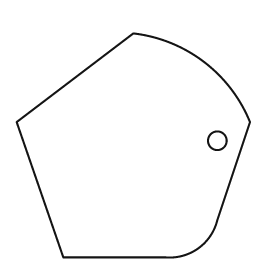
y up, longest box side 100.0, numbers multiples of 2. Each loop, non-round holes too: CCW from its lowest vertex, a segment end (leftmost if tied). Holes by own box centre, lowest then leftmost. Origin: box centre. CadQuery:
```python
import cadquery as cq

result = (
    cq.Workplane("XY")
    .moveTo(-30.0, -48.0)
    .lineTo(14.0, -48.0)
    .threePointArc((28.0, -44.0), (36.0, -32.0))
    .lineTo(50.0, 10.0)
    .threePointArc((30.0, 36.0), (0.0, 48.0))
    .lineTo(-50.0, 10.0)
    .close()
    .moveTo(36.0, 2.0)
    .circle(4.0)
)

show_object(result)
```